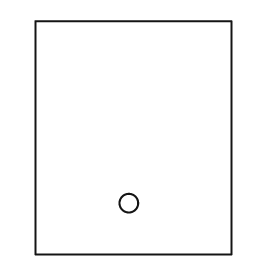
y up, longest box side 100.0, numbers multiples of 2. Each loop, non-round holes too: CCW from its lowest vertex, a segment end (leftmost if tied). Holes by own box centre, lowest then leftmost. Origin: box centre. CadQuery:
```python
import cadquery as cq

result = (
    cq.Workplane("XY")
    .moveTo(-42.0, -50.0)
    .lineTo(42.0, -50.0)
    .lineTo(42.0, 50.0)
    .lineTo(-42.0, 50.0)
    .close()
    .moveTo(-2.0, -28.0)
    .circle(4.0)
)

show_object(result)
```